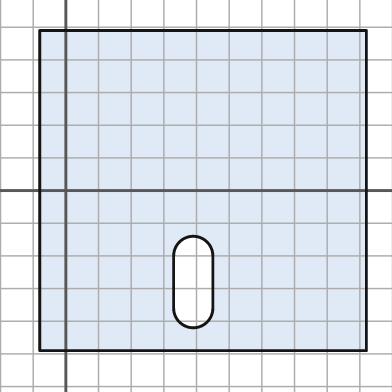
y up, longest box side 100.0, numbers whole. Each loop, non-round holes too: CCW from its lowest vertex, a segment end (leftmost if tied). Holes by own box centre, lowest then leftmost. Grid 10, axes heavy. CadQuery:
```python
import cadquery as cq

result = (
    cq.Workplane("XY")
    .moveTo(-8.0, -49.0)
    .lineTo(92.0, -49.0)
    .lineTo(92.0, 49.0)
    .lineTo(-8.0, 49.0)
    .close()
    .moveTo(33.0, -36.0)
    .threePointArc((39.0, -42.0), (45.0, -36.0))
    .lineTo(45.0, -20.0)
    .threePointArc((39.0, -14.0), (33.0, -20.0))
    .close()
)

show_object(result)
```